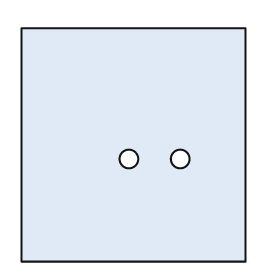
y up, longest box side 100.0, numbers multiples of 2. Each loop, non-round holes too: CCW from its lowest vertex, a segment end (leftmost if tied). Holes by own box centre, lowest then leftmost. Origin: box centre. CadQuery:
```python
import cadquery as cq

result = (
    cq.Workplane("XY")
    .moveTo(-48.0, -50.0)
    .lineTo(48.0, -50.0)
    .lineTo(48.0, 50.0)
    .lineTo(-48.0, 50.0)
    .close()
    .moveTo(-2.0, -6.0)
    .circle(4.0)
    .moveTo(20.0, -6.0)
    .circle(4.0)
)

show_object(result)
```